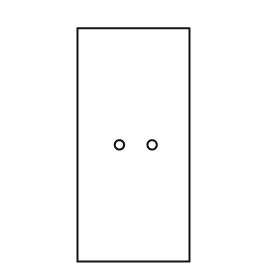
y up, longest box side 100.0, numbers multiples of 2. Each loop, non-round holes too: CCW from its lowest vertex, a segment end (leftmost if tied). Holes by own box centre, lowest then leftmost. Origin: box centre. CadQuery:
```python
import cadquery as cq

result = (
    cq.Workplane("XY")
    .moveTo(-24.0, -50.0)
    .lineTo(24.0, -50.0)
    .lineTo(24.0, 50.0)
    .lineTo(-24.0, 50.0)
    .close()
    .moveTo(-6.0, 0.0)
    .circle(2.0)
    .moveTo(8.0, 0.0)
    .circle(2.0)
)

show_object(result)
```